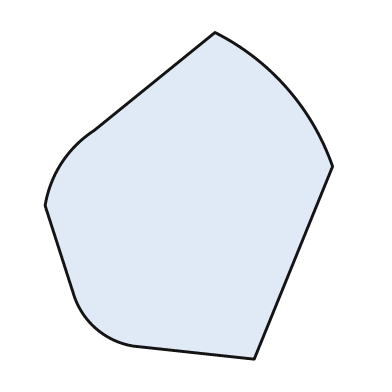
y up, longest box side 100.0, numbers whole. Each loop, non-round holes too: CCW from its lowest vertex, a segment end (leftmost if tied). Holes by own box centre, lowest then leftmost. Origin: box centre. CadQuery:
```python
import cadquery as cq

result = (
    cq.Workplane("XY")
    .moveTo(20.0, -50.0)
    .lineTo(44.0, 9.0)
    .threePointArc((30.0, 33.0), (8.0, 50.0))
    .lineTo(-29.0, 20.0)
    .threePointArc((-39.0, 10.0), (-44.0, -3.0))
    .lineTo(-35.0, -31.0)
    .threePointArc((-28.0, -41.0), (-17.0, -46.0))
    .close()
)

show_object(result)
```